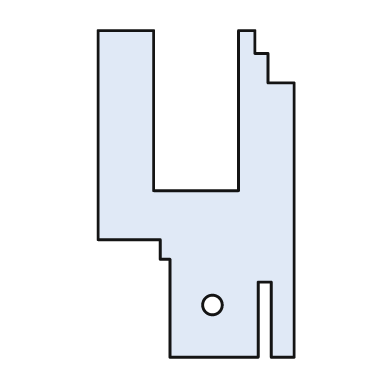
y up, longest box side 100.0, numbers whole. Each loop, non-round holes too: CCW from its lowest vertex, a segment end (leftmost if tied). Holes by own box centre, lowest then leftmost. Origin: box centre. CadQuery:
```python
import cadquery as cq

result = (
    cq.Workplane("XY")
    .moveTo(-8.0, -50.0)
    .lineTo(19.0, -50.0)
    .lineTo(19.0, -27.0)
    .lineTo(23.0, -27.0)
    .lineTo(23.0, -50.0)
    .lineTo(30.0, -50.0)
    .lineTo(30.0, 34.0)
    .lineTo(22.0, 34.0)
    .lineTo(22.0, 43.0)
    .lineTo(18.0, 43.0)
    .lineTo(18.0, 50.0)
    .lineTo(13.0, 50.0)
    .lineTo(13.0, 1.0)
    .lineTo(-13.0, 1.0)
    .lineTo(-13.0, 50.0)
    .lineTo(-30.0, 50.0)
    .lineTo(-30.0, -14.0)
    .lineTo(-11.0, -14.0)
    .lineTo(-11.0, -20.0)
    .lineTo(-8.0, -20.0)
    .close()
    .moveTo(5.0, -34.0)
    .circle(3.0)
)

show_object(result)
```